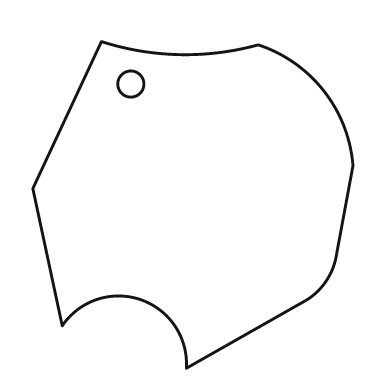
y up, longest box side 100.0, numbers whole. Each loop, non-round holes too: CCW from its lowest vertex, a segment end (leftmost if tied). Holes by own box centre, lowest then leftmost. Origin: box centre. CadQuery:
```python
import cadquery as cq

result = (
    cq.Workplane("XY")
    .moveTo(-2.0, -50.0)
    .lineTo(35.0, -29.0)
    .threePointArc((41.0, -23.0), (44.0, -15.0))
    .lineTo(49.0, 12.0)
    .threePointArc((40.0, 35.0), (20.0, 49.0))
    .threePointArc((-4.0, 46.0), (-28.0, 50.0))
    .lineTo(-49.0, 5.0)
    .lineTo(-40.0, -37.0)
    .threePointArc((-16.0, -29.0), (-2.0, -50.0))
    .close()
    .moveTo(-19.0, 37.0)
    .circle(4.0)
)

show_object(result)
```